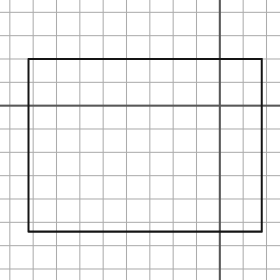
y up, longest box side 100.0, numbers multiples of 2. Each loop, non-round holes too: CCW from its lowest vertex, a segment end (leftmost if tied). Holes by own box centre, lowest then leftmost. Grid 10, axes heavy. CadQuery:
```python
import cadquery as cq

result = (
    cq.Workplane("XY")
    .moveTo(-82.0, -54.0)
    .lineTo(18.0, -54.0)
    .lineTo(18.0, 20.0)
    .lineTo(-82.0, 20.0)
    .close()
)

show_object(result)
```